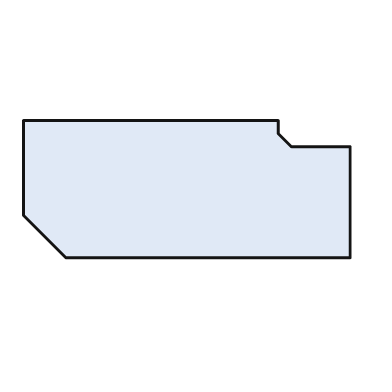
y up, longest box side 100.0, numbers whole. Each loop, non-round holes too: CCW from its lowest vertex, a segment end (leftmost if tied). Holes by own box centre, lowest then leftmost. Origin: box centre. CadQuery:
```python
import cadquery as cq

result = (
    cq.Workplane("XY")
    .moveTo(-37.0, -21.0)
    .lineTo(50.0, -21.0)
    .lineTo(50.0, 13.0)
    .lineTo(32.0, 13.0)
    .lineTo(28.0, 17.0)
    .lineTo(28.0, 21.0)
    .lineTo(-50.0, 21.0)
    .lineTo(-50.0, -8.0)
    .close()
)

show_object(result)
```